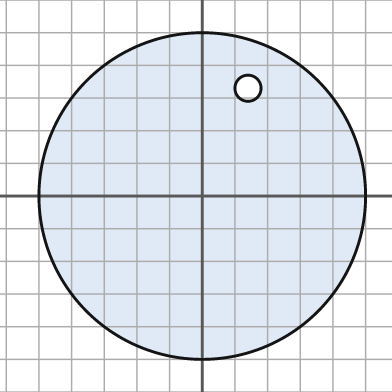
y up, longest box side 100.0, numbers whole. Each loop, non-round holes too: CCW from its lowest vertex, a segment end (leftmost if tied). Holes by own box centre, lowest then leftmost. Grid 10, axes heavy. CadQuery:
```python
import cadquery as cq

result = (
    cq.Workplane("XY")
    .moveTo(0.0, 0.0)
    .circle(50.0)
    .moveTo(14.0, 33.0)
    .circle(4.0)
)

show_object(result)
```